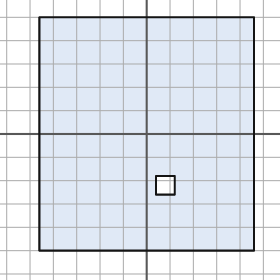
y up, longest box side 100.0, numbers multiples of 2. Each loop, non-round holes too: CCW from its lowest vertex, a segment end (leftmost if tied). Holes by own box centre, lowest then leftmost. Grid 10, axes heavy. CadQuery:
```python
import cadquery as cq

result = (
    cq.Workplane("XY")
    .moveTo(-46.0, -50.0)
    .lineTo(46.0, -50.0)
    .lineTo(46.0, 50.0)
    .lineTo(-46.0, 50.0)
    .close()
    .moveTo(4.0, -26.0)
    .lineTo(12.0, -26.0)
    .lineTo(12.0, -18.0)
    .lineTo(4.0, -18.0)
    .close()
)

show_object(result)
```